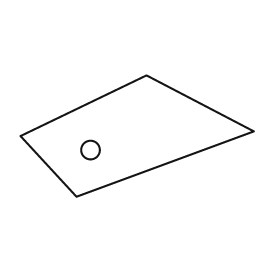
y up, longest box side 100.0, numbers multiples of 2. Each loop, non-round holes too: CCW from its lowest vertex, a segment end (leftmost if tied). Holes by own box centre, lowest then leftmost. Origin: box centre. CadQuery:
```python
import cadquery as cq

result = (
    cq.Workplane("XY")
    .moveTo(-26.0, -26.0)
    .lineTo(50.0, 2.0)
    .lineTo(4.0, 26.0)
    .lineTo(-50.0, 0.0)
    .close()
    .moveTo(-20.0, -6.0)
    .circle(4.0)
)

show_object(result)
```